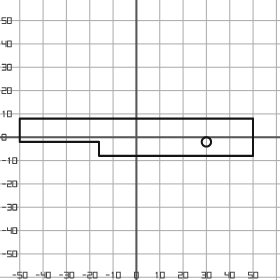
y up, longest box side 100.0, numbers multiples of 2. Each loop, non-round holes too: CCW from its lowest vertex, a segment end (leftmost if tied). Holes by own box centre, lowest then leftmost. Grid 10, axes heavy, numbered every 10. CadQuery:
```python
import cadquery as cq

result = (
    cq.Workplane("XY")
    .moveTo(-16.0, -8.0)
    .lineTo(50.0, -8.0)
    .lineTo(50.0, 8.0)
    .lineTo(-50.0, 8.0)
    .lineTo(-50.0, -2.0)
    .lineTo(-16.0, -2.0)
    .close()
    .moveTo(30.0, -2.0)
    .circle(2.0)
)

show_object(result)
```